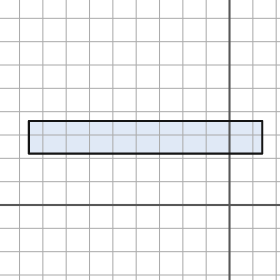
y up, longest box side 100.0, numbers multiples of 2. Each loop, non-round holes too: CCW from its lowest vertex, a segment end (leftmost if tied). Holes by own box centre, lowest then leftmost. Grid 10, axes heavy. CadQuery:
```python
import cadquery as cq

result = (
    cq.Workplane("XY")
    .moveTo(-86.0, 22.0)
    .lineTo(14.0, 22.0)
    .lineTo(14.0, 36.0)
    .lineTo(-86.0, 36.0)
    .close()
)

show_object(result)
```